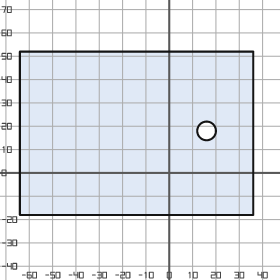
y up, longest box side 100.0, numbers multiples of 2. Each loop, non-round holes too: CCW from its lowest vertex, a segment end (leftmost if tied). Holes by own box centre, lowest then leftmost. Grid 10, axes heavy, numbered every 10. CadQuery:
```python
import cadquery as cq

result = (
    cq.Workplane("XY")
    .moveTo(-64.0, -18.0)
    .lineTo(36.0, -18.0)
    .lineTo(36.0, 52.0)
    .lineTo(-64.0, 52.0)
    .close()
    .moveTo(16.0, 18.0)
    .circle(4.0)
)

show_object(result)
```